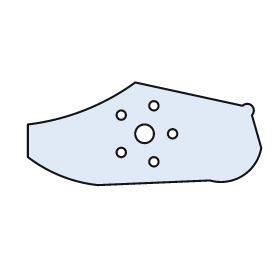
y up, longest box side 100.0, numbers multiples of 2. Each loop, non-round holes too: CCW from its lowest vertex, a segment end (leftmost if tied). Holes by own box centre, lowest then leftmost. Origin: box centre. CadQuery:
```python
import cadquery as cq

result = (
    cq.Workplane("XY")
    .moveTo(-20.0, -22.0)
    .lineTo(28.0, -20.0)
    .threePointArc((42.0, -18.0), (50.0, -6.0))
    .lineTo(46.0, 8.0)
    .threePointArc((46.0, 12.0), (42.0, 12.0))
    .lineTo(-4.0, 22.0)
    .threePointArc((-26.0, 10.0), (-50.0, 4.0))
    .lineTo(-50.0, -10.0)
    .threePointArc((-36.0, -18.0), (-20.0, -22.0))
    .close()
    .moveTo(4.0, -12.0)
    .circle(2.0)
    .moveTo(-10.0, -8.0)
    .circle(2.0)
    .moveTo(0.0, 0.0)
    .circle(4.0)
    .moveTo(12.0, 0.0)
    .circle(2.0)
    .moveTo(-10.0, 8.0)
    .circle(2.0)
    .moveTo(4.0, 12.0)
    .circle(2.0)
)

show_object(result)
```